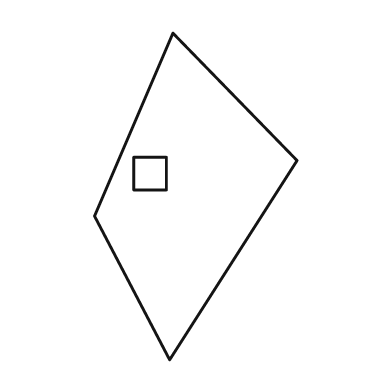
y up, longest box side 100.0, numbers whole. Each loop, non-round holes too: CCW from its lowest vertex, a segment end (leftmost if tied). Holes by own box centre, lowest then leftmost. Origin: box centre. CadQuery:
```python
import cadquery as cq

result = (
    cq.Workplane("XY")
    .moveTo(-8.0, -50.0)
    .lineTo(31.0, 11.0)
    .lineTo(-7.0, 50.0)
    .lineTo(-31.0, -6.0)
    .close()
    .moveTo(-19.0, 2.0)
    .lineTo(-9.0, 2.0)
    .lineTo(-9.0, 12.0)
    .lineTo(-19.0, 12.0)
    .close()
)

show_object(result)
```